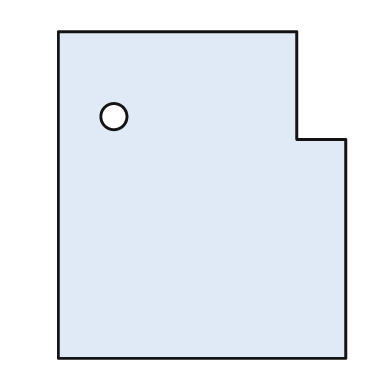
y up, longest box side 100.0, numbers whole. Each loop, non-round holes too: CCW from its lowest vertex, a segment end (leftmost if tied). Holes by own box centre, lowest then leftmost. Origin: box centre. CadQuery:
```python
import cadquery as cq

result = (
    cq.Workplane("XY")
    .moveTo(-44.0, -50.0)
    .lineTo(44.0, -50.0)
    .lineTo(44.0, 17.0)
    .lineTo(29.0, 17.0)
    .lineTo(29.0, 50.0)
    .lineTo(-44.0, 50.0)
    .close()
    .moveTo(-27.0, 24.0)
    .circle(4.0)
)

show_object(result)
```